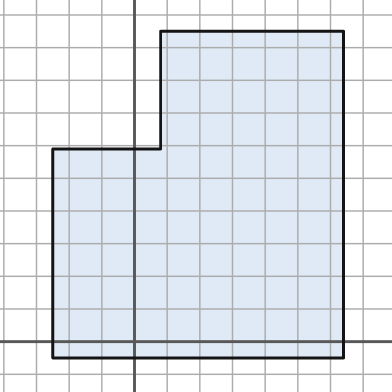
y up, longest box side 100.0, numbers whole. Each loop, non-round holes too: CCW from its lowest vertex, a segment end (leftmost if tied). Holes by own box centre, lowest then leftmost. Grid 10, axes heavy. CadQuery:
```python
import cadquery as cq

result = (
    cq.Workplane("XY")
    .moveTo(-25.0, -5.0)
    .lineTo(64.0, -5.0)
    .lineTo(64.0, 95.0)
    .lineTo(8.0, 95.0)
    .lineTo(8.0, 59.0)
    .lineTo(-25.0, 59.0)
    .close()
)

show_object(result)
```